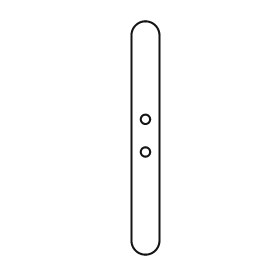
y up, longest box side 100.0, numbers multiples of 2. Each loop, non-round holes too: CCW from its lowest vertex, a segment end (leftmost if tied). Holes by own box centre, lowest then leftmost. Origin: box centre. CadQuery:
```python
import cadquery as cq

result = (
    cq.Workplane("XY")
    .moveTo(-6.0, -44.0)
    .threePointArc((0.0, -50.0), (6.0, -44.0))
    .lineTo(6.0, 44.0)
    .threePointArc((0.0, 50.0), (-6.0, 44.0))
    .close()
    .moveTo(0.0, -6.0)
    .circle(2.0)
    .moveTo(0.0, 8.0)
    .circle(2.0)
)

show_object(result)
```